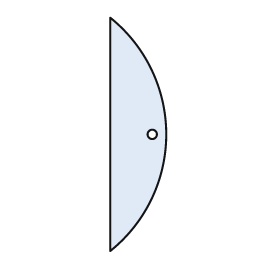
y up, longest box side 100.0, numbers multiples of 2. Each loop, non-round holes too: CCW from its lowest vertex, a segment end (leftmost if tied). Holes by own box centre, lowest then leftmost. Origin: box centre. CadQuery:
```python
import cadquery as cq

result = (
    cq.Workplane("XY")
    .moveTo(-12.0, -50.0)
    .threePointArc((12.0, 0.0), (-12.0, 50.0))
    .close()
    .moveTo(6.0, 0.0)
    .circle(2.0)
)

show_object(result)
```